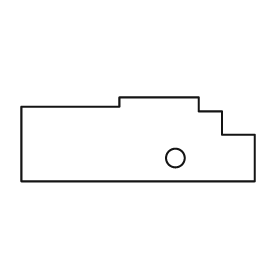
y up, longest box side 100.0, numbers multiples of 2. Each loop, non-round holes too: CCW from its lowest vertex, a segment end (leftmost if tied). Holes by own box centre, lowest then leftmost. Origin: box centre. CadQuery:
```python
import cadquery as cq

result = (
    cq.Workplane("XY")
    .moveTo(-50.0, -18.0)
    .lineTo(50.0, -18.0)
    .lineTo(50.0, 2.0)
    .lineTo(36.0, 2.0)
    .lineTo(36.0, 12.0)
    .lineTo(26.0, 12.0)
    .lineTo(26.0, 18.0)
    .lineTo(-8.0, 18.0)
    .lineTo(-8.0, 14.0)
    .lineTo(-50.0, 14.0)
    .close()
    .moveTo(16.0, -8.0)
    .circle(4.0)
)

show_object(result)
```